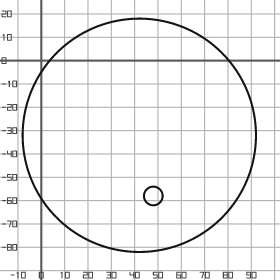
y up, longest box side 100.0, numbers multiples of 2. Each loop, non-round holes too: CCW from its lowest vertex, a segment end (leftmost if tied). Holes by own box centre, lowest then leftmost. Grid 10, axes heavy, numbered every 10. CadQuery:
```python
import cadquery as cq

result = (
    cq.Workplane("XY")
    .moveTo(42.0, -32.0)
    .circle(50.0)
    .moveTo(48.0, -58.0)
    .circle(4.0)
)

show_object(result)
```